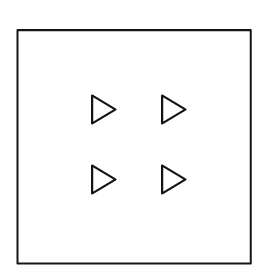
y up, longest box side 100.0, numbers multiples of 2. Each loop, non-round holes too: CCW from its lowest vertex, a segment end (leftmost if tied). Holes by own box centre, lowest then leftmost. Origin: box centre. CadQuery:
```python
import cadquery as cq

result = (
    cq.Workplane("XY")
    .moveTo(-50.0, -50.0)
    .lineTo(50.0, -50.0)
    .lineTo(50.0, 50.0)
    .lineTo(-50.0, 50.0)
    .close()
    .moveTo(-18.0, -20.0)
    .lineTo(-8.0, -14.0)
    .lineTo(-18.0, -8.0)
    .close()
    .moveTo(12.0, -20.0)
    .lineTo(22.0, -14.0)
    .lineTo(12.0, -8.0)
    .close()
    .moveTo(-18.0, 10.0)
    .lineTo(-8.0, 16.0)
    .lineTo(-18.0, 22.0)
    .close()
    .moveTo(12.0, 10.0)
    .lineTo(22.0, 16.0)
    .lineTo(12.0, 22.0)
    .close()
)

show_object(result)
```